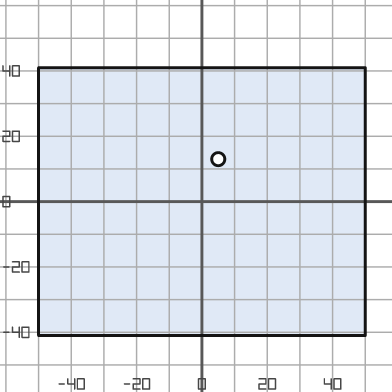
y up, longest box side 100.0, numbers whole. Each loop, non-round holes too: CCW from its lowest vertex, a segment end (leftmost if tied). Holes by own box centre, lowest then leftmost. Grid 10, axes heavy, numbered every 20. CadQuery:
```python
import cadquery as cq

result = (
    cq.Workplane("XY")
    .moveTo(-50.0, -41.0)
    .lineTo(50.0, -41.0)
    .lineTo(50.0, 41.0)
    .lineTo(-50.0, 41.0)
    .close()
    .moveTo(5.0, 13.0)
    .circle(2.0)
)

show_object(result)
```